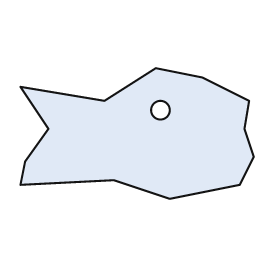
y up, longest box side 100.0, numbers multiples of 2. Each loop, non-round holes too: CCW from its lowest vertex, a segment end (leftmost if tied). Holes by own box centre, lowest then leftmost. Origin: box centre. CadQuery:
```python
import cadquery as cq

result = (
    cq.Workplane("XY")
    .moveTo(14.0, -28.0)
    .lineTo(44.0, -22.0)
    .lineTo(50.0, -10.0)
    .lineTo(46.0, 2.0)
    .lineTo(48.0, 14.0)
    .lineTo(28.0, 24.0)
    .lineTo(8.0, 28.0)
    .lineTo(-14.0, 14.0)
    .lineTo(-50.0, 20.0)
    .lineTo(-38.0, 2.0)
    .lineTo(-48.0, -12.0)
    .lineTo(-50.0, -22.0)
    .lineTo(-10.0, -20.0)
    .close()
    .moveTo(10.0, 10.0)
    .circle(4.0)
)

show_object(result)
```